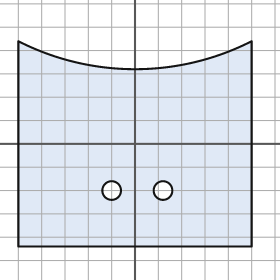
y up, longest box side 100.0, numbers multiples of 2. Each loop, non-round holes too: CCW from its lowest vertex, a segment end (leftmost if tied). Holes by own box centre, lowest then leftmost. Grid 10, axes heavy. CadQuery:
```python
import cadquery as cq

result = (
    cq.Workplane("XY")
    .moveTo(-50.0, -44.0)
    .lineTo(50.0, -44.0)
    .lineTo(50.0, 44.0)
    .threePointArc((0.0, 32.0), (-50.0, 44.0))
    .close()
    .moveTo(-10.0, -20.0)
    .circle(4.0)
    .moveTo(12.0, -20.0)
    .circle(4.0)
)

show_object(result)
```